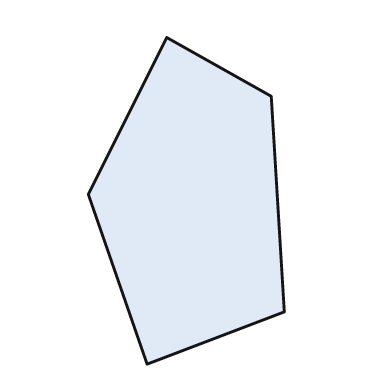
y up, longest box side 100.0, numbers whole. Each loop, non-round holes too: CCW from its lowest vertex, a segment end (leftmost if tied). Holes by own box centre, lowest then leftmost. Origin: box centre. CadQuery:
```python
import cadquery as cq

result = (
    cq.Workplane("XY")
    .moveTo(-12.0, -50.0)
    .lineTo(30.0, -34.0)
    .lineTo(26.0, 32.0)
    .lineTo(-6.0, 50.0)
    .lineTo(-30.0, 2.0)
    .close()
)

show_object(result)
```